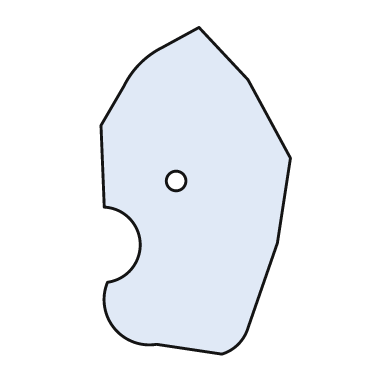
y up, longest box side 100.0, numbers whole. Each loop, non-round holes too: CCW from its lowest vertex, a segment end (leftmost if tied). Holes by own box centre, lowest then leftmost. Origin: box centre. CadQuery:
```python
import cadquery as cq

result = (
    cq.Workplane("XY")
    .moveTo(8.0, -50.0)
    .threePointArc((13.0, -47.0), (16.0, -42.0))
    .lineTo(25.0, -16.0)
    .lineTo(29.0, 10.0)
    .lineTo(16.0, 34.0)
    .lineTo(1.0, 50.0)
    .lineTo(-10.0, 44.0)
    .threePointArc((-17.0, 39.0), (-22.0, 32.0))
    .lineTo(-29.0, 20.0)
    .lineTo(-28.0, -5.0)
    .threePointArc((-17.0, -16.0), (-27.0, -28.0))
    .threePointArc((-25.0, -42.0), (-12.0, -47.0))
    .close()
    .moveTo(-6.0, 3.0)
    .circle(3.0)
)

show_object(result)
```